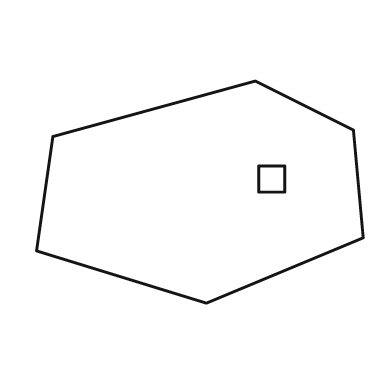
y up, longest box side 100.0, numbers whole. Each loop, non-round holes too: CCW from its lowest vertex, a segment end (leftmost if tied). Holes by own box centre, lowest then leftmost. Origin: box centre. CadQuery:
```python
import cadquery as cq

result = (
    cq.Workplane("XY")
    .moveTo(2.0, -34.0)
    .lineTo(50.0, -14.0)
    .lineTo(47.0, 19.0)
    .lineTo(17.0, 34.0)
    .lineTo(-45.0, 17.0)
    .lineTo(-50.0, -18.0)
    .close()
    .moveTo(18.0, 0.0)
    .lineTo(26.0, 0.0)
    .lineTo(26.0, 8.0)
    .lineTo(18.0, 8.0)
    .close()
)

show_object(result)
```